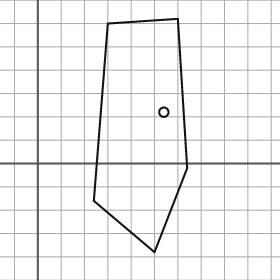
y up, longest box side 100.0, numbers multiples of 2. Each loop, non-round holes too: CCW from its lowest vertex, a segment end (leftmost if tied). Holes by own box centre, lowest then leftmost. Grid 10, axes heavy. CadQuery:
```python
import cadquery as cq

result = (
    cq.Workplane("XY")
    .moveTo(50.0, -38.0)
    .lineTo(64.0, -2.0)
    .lineTo(60.0, 62.0)
    .lineTo(30.0, 60.0)
    .lineTo(24.0, -16.0)
    .close()
    .moveTo(54.0, 22.0)
    .circle(2.0)
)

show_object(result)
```